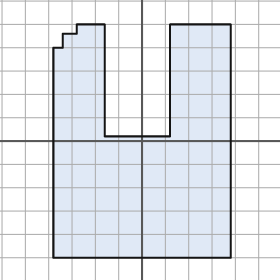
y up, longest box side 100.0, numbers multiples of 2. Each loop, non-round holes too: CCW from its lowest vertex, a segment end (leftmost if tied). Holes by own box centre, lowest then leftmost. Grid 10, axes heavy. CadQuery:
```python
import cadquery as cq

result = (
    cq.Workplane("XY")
    .moveTo(-38.0, -50.0)
    .lineTo(38.0, -50.0)
    .lineTo(38.0, 50.0)
    .lineTo(12.0, 50.0)
    .lineTo(12.0, 2.0)
    .lineTo(-16.0, 2.0)
    .lineTo(-16.0, 50.0)
    .lineTo(-28.0, 50.0)
    .lineTo(-28.0, 46.0)
    .lineTo(-34.0, 46.0)
    .lineTo(-34.0, 40.0)
    .lineTo(-38.0, 40.0)
    .close()
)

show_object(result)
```